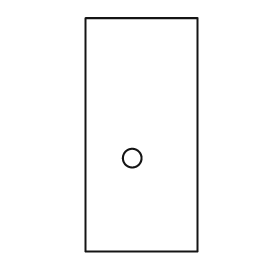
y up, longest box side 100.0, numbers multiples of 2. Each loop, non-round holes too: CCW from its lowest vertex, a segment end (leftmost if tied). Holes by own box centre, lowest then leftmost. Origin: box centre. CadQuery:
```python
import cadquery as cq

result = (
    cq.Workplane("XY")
    .moveTo(-24.0, -50.0)
    .lineTo(24.0, -50.0)
    .lineTo(24.0, 50.0)
    .lineTo(-24.0, 50.0)
    .close()
    .moveTo(-4.0, -10.0)
    .circle(4.0)
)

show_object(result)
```